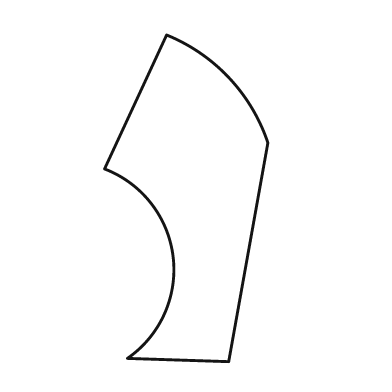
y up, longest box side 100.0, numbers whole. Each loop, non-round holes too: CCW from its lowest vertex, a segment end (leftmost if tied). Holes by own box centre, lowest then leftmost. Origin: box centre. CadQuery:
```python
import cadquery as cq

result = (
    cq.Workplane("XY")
    .moveTo(13.0, -50.0)
    .lineTo(25.0, 17.0)
    .threePointArc((13.0, 37.0), (-6.0, 50.0))
    .lineTo(-25.0, 9.0)
    .threePointArc((-4.0, -18.0), (-18.0, -49.0))
    .close()
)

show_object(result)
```